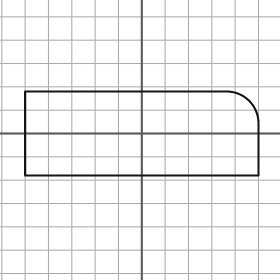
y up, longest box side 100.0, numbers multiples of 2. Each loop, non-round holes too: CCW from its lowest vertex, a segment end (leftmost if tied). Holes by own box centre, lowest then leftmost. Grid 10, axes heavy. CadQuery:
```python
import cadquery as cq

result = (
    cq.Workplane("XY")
    .moveTo(-50.0, -18.0)
    .lineTo(50.0, -18.0)
    .lineTo(50.0, 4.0)
    .threePointArc((46.0, 14.0), (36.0, 18.0))
    .lineTo(-50.0, 18.0)
    .close()
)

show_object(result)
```